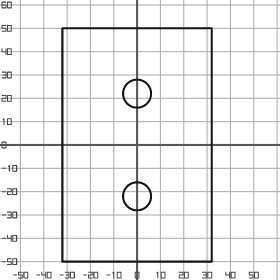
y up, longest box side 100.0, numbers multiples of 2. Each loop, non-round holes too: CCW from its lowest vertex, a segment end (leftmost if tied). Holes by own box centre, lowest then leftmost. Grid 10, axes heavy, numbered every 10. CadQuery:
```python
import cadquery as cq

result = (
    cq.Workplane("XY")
    .moveTo(-32.0, -50.0)
    .lineTo(32.0, -50.0)
    .lineTo(32.0, 50.0)
    .lineTo(-32.0, 50.0)
    .close()
    .moveTo(0.0, -22.0)
    .circle(6.0)
    .moveTo(0.0, 22.0)
    .circle(6.0)
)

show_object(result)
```